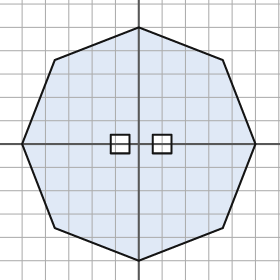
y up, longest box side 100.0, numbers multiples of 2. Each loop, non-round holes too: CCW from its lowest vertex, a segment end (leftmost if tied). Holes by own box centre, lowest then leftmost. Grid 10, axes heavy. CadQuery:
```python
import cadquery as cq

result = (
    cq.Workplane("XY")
    .moveTo(0.0, -50.0)
    .lineTo(36.0, -36.0)
    .lineTo(50.0, 0.0)
    .lineTo(36.0, 36.0)
    .lineTo(0.0, 50.0)
    .lineTo(-36.0, 36.0)
    .lineTo(-50.0, 0.0)
    .lineTo(-36.0, -36.0)
    .close()
    .moveTo(-12.0, -4.0)
    .lineTo(-4.0, -4.0)
    .lineTo(-4.0, 4.0)
    .lineTo(-12.0, 4.0)
    .close()
    .moveTo(6.0, -4.0)
    .lineTo(14.0, -4.0)
    .lineTo(14.0, 4.0)
    .lineTo(6.0, 4.0)
    .close()
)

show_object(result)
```